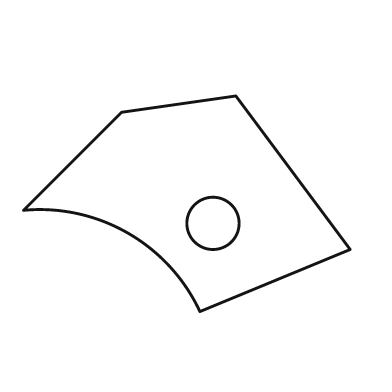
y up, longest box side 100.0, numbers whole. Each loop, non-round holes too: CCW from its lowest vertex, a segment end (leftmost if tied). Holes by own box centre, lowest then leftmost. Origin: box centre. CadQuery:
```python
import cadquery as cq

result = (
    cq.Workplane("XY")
    .moveTo(4.0, -33.0)
    .lineTo(50.0, -14.0)
    .lineTo(15.0, 33.0)
    .lineTo(-20.0, 28.0)
    .lineTo(-50.0, -2.0)
    .threePointArc((-18.0, -9.0), (4.0, -33.0))
    .close()
    .moveTo(8.0, -6.0)
    .circle(8.0)
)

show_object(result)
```